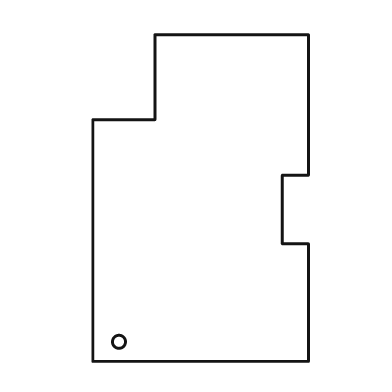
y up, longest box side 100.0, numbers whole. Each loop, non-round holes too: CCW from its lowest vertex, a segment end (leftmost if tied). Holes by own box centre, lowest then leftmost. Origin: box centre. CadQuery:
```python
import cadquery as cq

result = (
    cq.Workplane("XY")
    .moveTo(-33.0, -50.0)
    .lineTo(33.0, -50.0)
    .lineTo(33.0, -14.0)
    .lineTo(25.0, -14.0)
    .lineTo(25.0, 7.0)
    .lineTo(33.0, 7.0)
    .lineTo(33.0, 50.0)
    .lineTo(-14.0, 50.0)
    .lineTo(-14.0, 24.0)
    .lineTo(-33.0, 24.0)
    .close()
    .moveTo(-25.0, -44.0)
    .circle(2.0)
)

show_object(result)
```